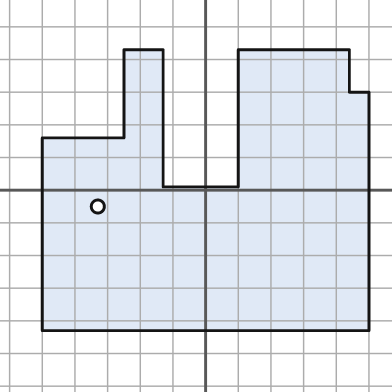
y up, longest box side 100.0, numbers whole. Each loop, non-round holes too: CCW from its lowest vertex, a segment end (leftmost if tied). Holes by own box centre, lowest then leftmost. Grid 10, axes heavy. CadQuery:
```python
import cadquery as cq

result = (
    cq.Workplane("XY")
    .moveTo(-50.0, -43.0)
    .lineTo(50.0, -43.0)
    .lineTo(50.0, 30.0)
    .lineTo(44.0, 30.0)
    .lineTo(44.0, 43.0)
    .lineTo(10.0, 43.0)
    .lineTo(10.0, 1.0)
    .lineTo(-13.0, 1.0)
    .lineTo(-13.0, 43.0)
    .lineTo(-25.0, 43.0)
    .lineTo(-25.0, 16.0)
    .lineTo(-50.0, 16.0)
    .close()
    .moveTo(-33.0, -5.0)
    .circle(2.0)
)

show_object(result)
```